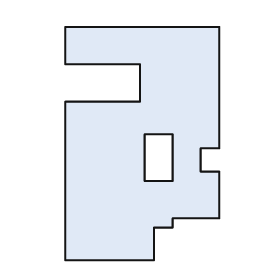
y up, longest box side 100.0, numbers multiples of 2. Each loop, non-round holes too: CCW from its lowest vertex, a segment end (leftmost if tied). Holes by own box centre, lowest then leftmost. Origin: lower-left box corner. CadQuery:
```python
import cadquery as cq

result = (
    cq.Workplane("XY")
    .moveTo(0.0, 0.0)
    .lineTo(38.0, 0.0)
    .lineTo(38.0, 14.0)
    .lineTo(46.0, 14.0)
    .lineTo(46.0, 18.0)
    .lineTo(66.0, 18.0)
    .lineTo(66.0, 38.0)
    .lineTo(58.0, 38.0)
    .lineTo(58.0, 48.0)
    .lineTo(66.0, 48.0)
    .lineTo(66.0, 100.0)
    .lineTo(0.0, 100.0)
    .lineTo(0.0, 84.0)
    .lineTo(32.0, 84.0)
    .lineTo(32.0, 68.0)
    .lineTo(0.0, 68.0)
    .close()
    .moveTo(34.0, 34.0)
    .lineTo(46.0, 34.0)
    .lineTo(46.0, 54.0)
    .lineTo(34.0, 54.0)
    .close()
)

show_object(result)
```